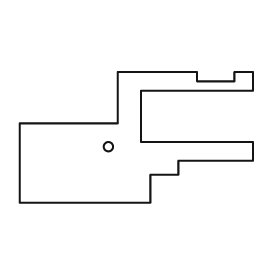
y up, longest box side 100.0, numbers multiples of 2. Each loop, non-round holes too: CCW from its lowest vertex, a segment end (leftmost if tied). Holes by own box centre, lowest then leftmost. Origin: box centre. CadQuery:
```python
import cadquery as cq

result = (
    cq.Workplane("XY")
    .moveTo(-50.0, -28.0)
    .lineTo(6.0, -28.0)
    .lineTo(6.0, -16.0)
    .lineTo(18.0, -16.0)
    .lineTo(18.0, -10.0)
    .lineTo(50.0, -10.0)
    .lineTo(50.0, -2.0)
    .lineTo(2.0, -2.0)
    .lineTo(2.0, 20.0)
    .lineTo(50.0, 20.0)
    .lineTo(50.0, 28.0)
    .lineTo(42.0, 28.0)
    .lineTo(42.0, 24.0)
    .lineTo(26.0, 24.0)
    .lineTo(26.0, 28.0)
    .lineTo(-8.0, 28.0)
    .lineTo(-8.0, 6.0)
    .lineTo(-50.0, 6.0)
    .close()
    .moveTo(-12.0, -4.0)
    .circle(2.0)
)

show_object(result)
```